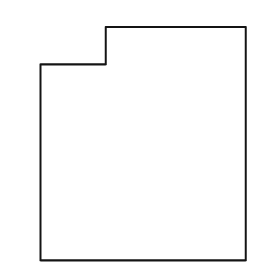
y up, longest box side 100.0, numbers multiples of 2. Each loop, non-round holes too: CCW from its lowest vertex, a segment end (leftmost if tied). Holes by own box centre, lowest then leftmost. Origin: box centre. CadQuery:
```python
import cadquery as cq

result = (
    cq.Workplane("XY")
    .moveTo(-44.0, -50.0)
    .lineTo(44.0, -50.0)
    .lineTo(44.0, 50.0)
    .lineTo(-16.0, 50.0)
    .lineTo(-16.0, 34.0)
    .lineTo(-44.0, 34.0)
    .close()
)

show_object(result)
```